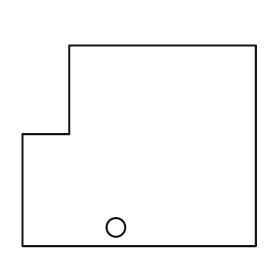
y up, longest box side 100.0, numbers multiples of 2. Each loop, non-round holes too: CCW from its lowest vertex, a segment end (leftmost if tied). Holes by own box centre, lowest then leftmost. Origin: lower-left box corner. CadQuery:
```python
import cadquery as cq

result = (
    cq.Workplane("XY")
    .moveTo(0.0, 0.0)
    .lineTo(100.0, 0.0)
    .lineTo(100.0, 86.0)
    .lineTo(20.0, 86.0)
    .lineTo(20.0, 48.0)
    .lineTo(0.0, 48.0)
    .close()
    .moveTo(40.0, 8.0)
    .circle(4.0)
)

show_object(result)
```